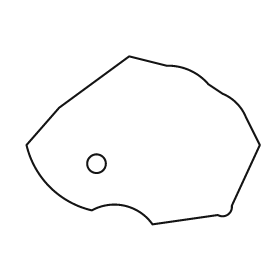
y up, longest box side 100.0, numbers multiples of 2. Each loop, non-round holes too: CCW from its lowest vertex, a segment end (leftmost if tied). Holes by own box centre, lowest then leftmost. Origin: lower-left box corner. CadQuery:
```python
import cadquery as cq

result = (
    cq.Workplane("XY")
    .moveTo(54.0, 0.0)
    .lineTo(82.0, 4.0)
    .threePointArc((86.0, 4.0), (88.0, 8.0))
    .lineTo(100.0, 34.0)
    .lineTo(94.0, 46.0)
    .threePointArc((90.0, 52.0), (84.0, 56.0))
    .lineTo(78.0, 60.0)
    .threePointArc((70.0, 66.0), (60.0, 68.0))
    .lineTo(44.0, 72.0)
    .lineTo(14.0, 50.0)
    .lineTo(0.0, 34.0)
    .threePointArc((10.0, 16.0), (28.0, 6.0))
    .threePointArc((42.0, 8.0), (54.0, 0.0))
    .close()
    .moveTo(30.0, 26.0)
    .circle(4.0)
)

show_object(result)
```